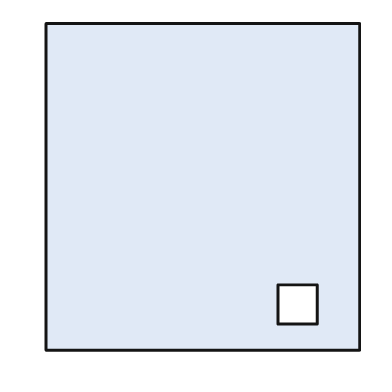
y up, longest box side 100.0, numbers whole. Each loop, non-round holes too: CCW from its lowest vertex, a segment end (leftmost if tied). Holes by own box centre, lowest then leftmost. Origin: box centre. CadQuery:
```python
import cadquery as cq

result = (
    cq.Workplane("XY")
    .moveTo(-48.0, -50.0)
    .lineTo(48.0, -50.0)
    .lineTo(48.0, 50.0)
    .lineTo(-48.0, 50.0)
    .close()
    .moveTo(23.0, -42.0)
    .lineTo(35.0, -42.0)
    .lineTo(35.0, -30.0)
    .lineTo(23.0, -30.0)
    .close()
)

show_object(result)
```